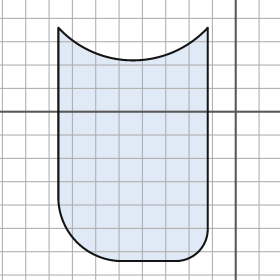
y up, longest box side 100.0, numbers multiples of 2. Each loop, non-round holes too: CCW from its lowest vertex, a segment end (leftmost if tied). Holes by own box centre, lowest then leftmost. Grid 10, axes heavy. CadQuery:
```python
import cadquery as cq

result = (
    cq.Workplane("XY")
    .moveTo(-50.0, -64.0)
    .lineTo(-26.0, -64.0)
    .threePointArc((-16.0, -60.0), (-12.0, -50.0))
    .lineTo(-12.0, 36.0)
    .threePointArc((-44.0, 22.0), (-76.0, 36.0))
    .lineTo(-76.0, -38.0)
    .threePointArc((-68.0, -56.0), (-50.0, -64.0))
    .close()
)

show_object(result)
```